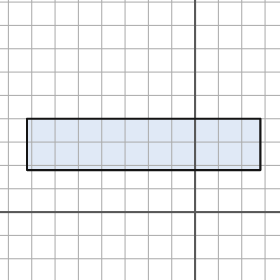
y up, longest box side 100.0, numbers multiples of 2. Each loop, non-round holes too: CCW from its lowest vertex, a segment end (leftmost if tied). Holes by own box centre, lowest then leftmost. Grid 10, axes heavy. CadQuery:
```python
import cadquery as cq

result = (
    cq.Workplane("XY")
    .moveTo(-72.0, 18.0)
    .lineTo(28.0, 18.0)
    .lineTo(28.0, 40.0)
    .lineTo(-72.0, 40.0)
    .close()
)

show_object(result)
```